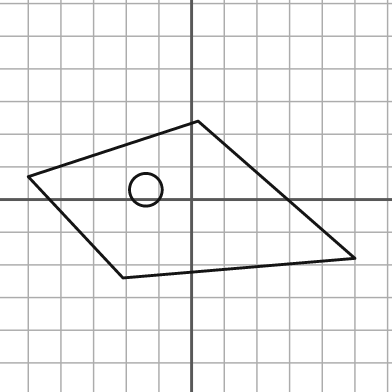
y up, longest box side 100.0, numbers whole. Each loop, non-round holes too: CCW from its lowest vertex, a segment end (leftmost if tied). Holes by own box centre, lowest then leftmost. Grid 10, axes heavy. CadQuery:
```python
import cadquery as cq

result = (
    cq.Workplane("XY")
    .moveTo(-21.0, -24.0)
    .lineTo(50.0, -18.0)
    .lineTo(2.0, 24.0)
    .lineTo(-50.0, 7.0)
    .close()
    .moveTo(-14.0, 3.0)
    .circle(5.0)
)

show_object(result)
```